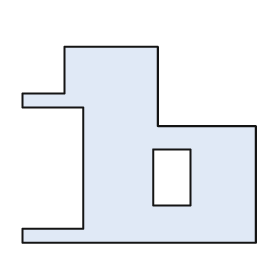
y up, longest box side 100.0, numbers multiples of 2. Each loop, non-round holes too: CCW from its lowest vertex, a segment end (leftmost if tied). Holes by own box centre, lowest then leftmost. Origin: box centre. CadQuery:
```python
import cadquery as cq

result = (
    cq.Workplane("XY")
    .moveTo(-50.0, -42.0)
    .lineTo(50.0, -42.0)
    .lineTo(50.0, 8.0)
    .lineTo(8.0, 8.0)
    .lineTo(8.0, 42.0)
    .lineTo(-32.0, 42.0)
    .lineTo(-32.0, 22.0)
    .lineTo(-50.0, 22.0)
    .lineTo(-50.0, 16.0)
    .lineTo(-24.0, 16.0)
    .lineTo(-24.0, -36.0)
    .lineTo(-50.0, -36.0)
    .close()
    .moveTo(6.0, -26.0)
    .lineTo(22.0, -26.0)
    .lineTo(22.0, -2.0)
    .lineTo(6.0, -2.0)
    .close()
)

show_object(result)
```